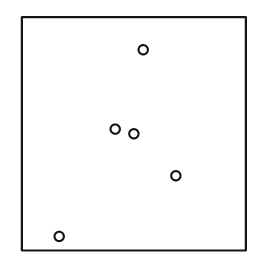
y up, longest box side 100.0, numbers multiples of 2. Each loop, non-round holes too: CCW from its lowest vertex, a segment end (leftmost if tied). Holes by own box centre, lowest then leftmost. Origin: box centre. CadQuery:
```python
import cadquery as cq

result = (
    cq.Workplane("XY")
    .moveTo(-48.0, -50.0)
    .lineTo(48.0, -50.0)
    .lineTo(48.0, 50.0)
    .lineTo(-48.0, 50.0)
    .close()
    .moveTo(-32.0, -44.0)
    .circle(2.0)
    .moveTo(18.0, -18.0)
    .circle(2.0)
    .moveTo(0.0, 0.0)
    .circle(2.0)
    .moveTo(-8.0, 2.0)
    .circle(2.0)
    .moveTo(4.0, 36.0)
    .circle(2.0)
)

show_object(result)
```